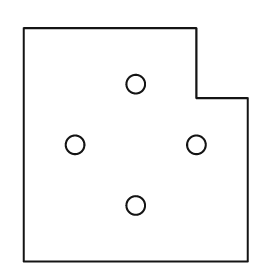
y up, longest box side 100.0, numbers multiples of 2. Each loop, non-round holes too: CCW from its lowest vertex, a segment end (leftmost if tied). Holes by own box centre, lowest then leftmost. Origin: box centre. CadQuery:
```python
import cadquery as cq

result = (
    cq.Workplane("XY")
    .moveTo(-48.0, -50.0)
    .lineTo(48.0, -50.0)
    .lineTo(48.0, 20.0)
    .lineTo(26.0, 20.0)
    .lineTo(26.0, 50.0)
    .lineTo(-48.0, 50.0)
    .close()
    .moveTo(0.0, -26.0)
    .circle(4.0)
    .moveTo(-26.0, 0.0)
    .circle(4.0)
    .moveTo(26.0, 0.0)
    .circle(4.0)
    .moveTo(0.0, 26.0)
    .circle(4.0)
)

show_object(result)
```